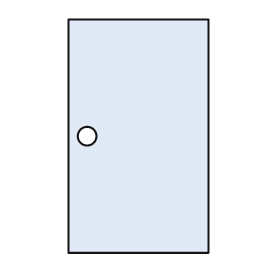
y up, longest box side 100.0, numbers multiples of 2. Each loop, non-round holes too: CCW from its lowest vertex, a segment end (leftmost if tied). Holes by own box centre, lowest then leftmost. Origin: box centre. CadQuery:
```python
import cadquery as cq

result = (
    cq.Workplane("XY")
    .moveTo(-30.0, -50.0)
    .lineTo(30.0, -50.0)
    .lineTo(30.0, 50.0)
    .lineTo(-30.0, 50.0)
    .close()
    .moveTo(-22.0, 0.0)
    .circle(4.0)
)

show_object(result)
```